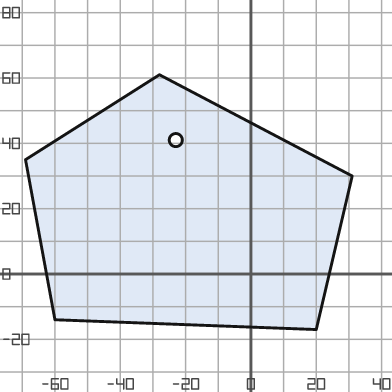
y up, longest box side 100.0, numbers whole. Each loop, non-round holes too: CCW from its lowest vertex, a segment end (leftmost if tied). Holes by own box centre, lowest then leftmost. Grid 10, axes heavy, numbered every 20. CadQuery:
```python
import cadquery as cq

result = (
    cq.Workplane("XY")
    .moveTo(20.0, -17.0)
    .lineTo(31.0, 30.0)
    .lineTo(-28.0, 61.0)
    .lineTo(-69.0, 35.0)
    .lineTo(-60.0, -14.0)
    .close()
    .moveTo(-23.0, 41.0)
    .circle(2.0)
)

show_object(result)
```